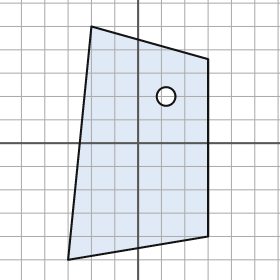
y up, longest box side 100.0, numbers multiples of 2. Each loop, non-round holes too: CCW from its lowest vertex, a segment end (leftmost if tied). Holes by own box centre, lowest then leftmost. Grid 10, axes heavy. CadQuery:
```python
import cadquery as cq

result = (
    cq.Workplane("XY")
    .moveTo(-30.0, -50.0)
    .lineTo(30.0, -40.0)
    .lineTo(30.0, 36.0)
    .lineTo(-20.0, 50.0)
    .close()
    .moveTo(12.0, 20.0)
    .circle(4.0)
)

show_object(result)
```